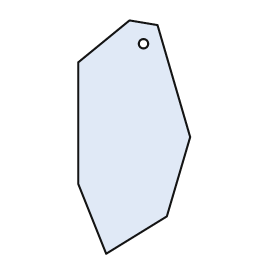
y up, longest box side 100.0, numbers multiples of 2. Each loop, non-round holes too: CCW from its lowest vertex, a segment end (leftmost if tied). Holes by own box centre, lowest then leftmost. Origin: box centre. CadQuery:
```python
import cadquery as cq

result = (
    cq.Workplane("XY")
    .moveTo(-12.0, -50.0)
    .lineTo(14.0, -34.0)
    .lineTo(24.0, 0.0)
    .lineTo(10.0, 48.0)
    .lineTo(-2.0, 50.0)
    .lineTo(-24.0, 32.0)
    .lineTo(-24.0, -20.0)
    .close()
    .moveTo(4.0, 40.0)
    .circle(2.0)
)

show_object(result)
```